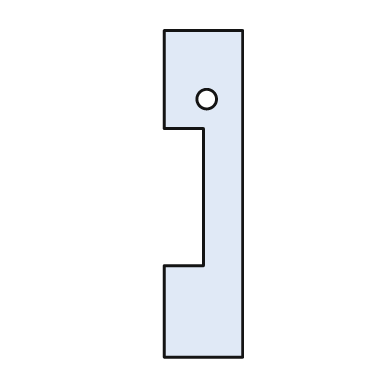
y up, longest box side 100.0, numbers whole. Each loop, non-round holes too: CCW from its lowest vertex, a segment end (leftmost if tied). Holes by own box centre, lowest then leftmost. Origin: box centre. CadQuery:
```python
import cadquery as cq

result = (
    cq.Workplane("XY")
    .moveTo(-12.0, -50.0)
    .lineTo(12.0, -50.0)
    .lineTo(12.0, 50.0)
    .lineTo(-12.0, 50.0)
    .lineTo(-12.0, 20.0)
    .lineTo(0.0, 20.0)
    .lineTo(0.0, -22.0)
    .lineTo(-12.0, -22.0)
    .close()
    .moveTo(1.0, 29.0)
    .circle(3.0)
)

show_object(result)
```